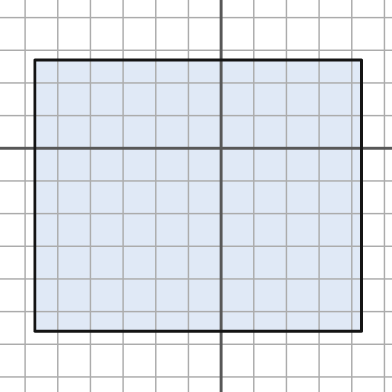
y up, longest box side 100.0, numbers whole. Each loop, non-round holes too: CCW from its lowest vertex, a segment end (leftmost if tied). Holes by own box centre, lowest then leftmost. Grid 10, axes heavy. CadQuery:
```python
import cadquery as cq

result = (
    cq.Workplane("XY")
    .moveTo(-57.0, -56.0)
    .lineTo(43.0, -56.0)
    .lineTo(43.0, 27.0)
    .lineTo(-57.0, 27.0)
    .close()
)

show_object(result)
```